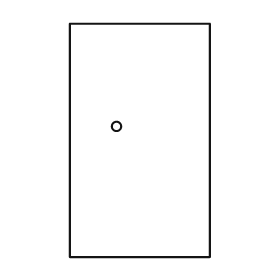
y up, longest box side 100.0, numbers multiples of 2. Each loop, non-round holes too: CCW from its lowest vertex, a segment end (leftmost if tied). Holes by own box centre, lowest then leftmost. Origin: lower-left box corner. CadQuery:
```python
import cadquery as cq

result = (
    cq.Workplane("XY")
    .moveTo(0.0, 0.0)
    .lineTo(60.0, 0.0)
    .lineTo(60.0, 100.0)
    .lineTo(0.0, 100.0)
    .close()
    .moveTo(20.0, 56.0)
    .circle(2.0)
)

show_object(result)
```